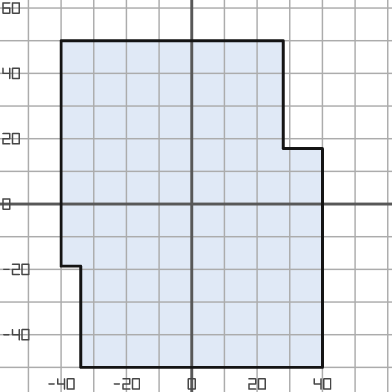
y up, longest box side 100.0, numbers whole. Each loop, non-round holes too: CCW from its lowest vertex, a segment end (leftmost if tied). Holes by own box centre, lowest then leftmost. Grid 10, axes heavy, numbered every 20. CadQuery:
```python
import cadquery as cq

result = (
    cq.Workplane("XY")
    .moveTo(-34.0, -50.0)
    .lineTo(40.0, -50.0)
    .lineTo(40.0, 17.0)
    .lineTo(28.0, 17.0)
    .lineTo(28.0, 50.0)
    .lineTo(-40.0, 50.0)
    .lineTo(-40.0, -19.0)
    .lineTo(-34.0, -19.0)
    .close()
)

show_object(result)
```